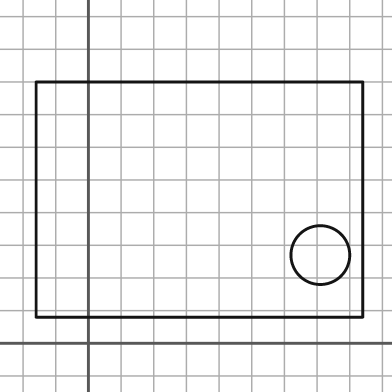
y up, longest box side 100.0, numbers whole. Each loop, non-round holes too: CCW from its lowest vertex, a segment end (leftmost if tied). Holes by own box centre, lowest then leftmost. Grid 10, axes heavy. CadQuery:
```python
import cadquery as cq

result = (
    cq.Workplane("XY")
    .moveTo(-16.0, 8.0)
    .lineTo(84.0, 8.0)
    .lineTo(84.0, 80.0)
    .lineTo(-16.0, 80.0)
    .close()
    .moveTo(71.0, 27.0)
    .circle(9.0)
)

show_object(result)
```